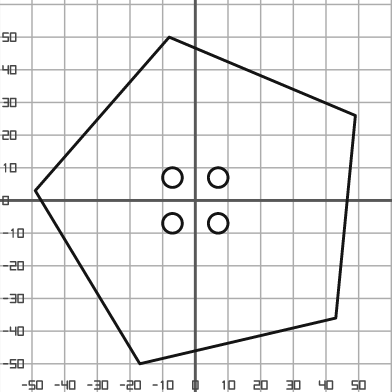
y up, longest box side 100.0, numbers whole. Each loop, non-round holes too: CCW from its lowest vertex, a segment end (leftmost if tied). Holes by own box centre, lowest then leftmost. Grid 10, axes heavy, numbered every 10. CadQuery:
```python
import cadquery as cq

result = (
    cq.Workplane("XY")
    .moveTo(-17.0, -50.0)
    .lineTo(43.0, -36.0)
    .lineTo(49.0, 26.0)
    .lineTo(-8.0, 50.0)
    .lineTo(-49.0, 3.0)
    .close()
    .moveTo(-7.0, -7.0)
    .circle(3.0)
    .moveTo(7.0, -7.0)
    .circle(3.0)
    .moveTo(-7.0, 7.0)
    .circle(3.0)
    .moveTo(7.0, 7.0)
    .circle(3.0)
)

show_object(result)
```